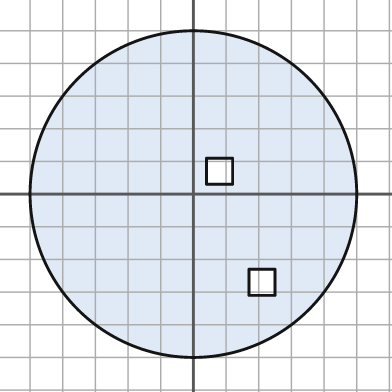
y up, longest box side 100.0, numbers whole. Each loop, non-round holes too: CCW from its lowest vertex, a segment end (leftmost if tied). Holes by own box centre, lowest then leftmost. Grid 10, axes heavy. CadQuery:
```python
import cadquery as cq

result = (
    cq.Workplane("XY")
    .moveTo(0.0, 0.0)
    .circle(50.0)
    .moveTo(17.0, -31.0)
    .lineTo(25.0, -31.0)
    .lineTo(25.0, -23.0)
    .lineTo(17.0, -23.0)
    .close()
    .moveTo(4.0, 3.0)
    .lineTo(12.0, 3.0)
    .lineTo(12.0, 11.0)
    .lineTo(4.0, 11.0)
    .close()
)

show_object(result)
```